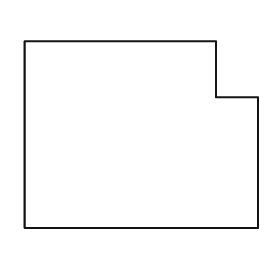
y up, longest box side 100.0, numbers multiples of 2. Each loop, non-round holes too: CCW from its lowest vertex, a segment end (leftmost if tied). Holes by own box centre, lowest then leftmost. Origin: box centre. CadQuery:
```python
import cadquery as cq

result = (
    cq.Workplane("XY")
    .moveTo(-50.0, -40.0)
    .lineTo(50.0, -40.0)
    .lineTo(50.0, 16.0)
    .lineTo(32.0, 16.0)
    .lineTo(32.0, 40.0)
    .lineTo(-50.0, 40.0)
    .close()
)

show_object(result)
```